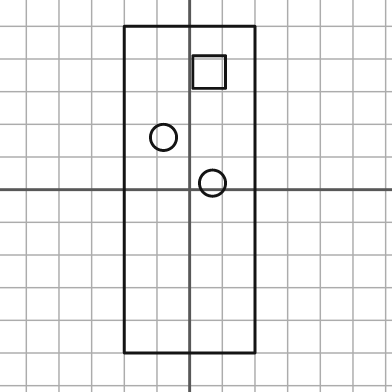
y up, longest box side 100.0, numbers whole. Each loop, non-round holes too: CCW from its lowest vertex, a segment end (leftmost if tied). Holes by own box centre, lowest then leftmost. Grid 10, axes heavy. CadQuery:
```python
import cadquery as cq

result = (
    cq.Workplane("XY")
    .moveTo(-20.0, -50.0)
    .lineTo(20.0, -50.0)
    .lineTo(20.0, 50.0)
    .lineTo(-20.0, 50.0)
    .close()
    .moveTo(7.0, 2.0)
    .circle(4.0)
    .moveTo(-8.0, 16.0)
    .circle(4.0)
    .moveTo(1.0, 31.0)
    .lineTo(11.0, 31.0)
    .lineTo(11.0, 41.0)
    .lineTo(1.0, 41.0)
    .close()
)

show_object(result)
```